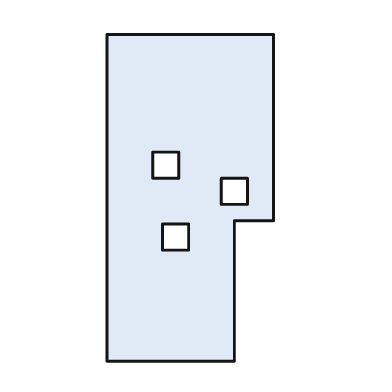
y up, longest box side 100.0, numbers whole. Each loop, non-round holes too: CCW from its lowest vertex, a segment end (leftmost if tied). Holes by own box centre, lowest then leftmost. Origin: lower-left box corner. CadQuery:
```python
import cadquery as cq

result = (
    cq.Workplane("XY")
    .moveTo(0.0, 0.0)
    .lineTo(39.0, 0.0)
    .lineTo(39.0, 43.0)
    .lineTo(51.0, 43.0)
    .lineTo(51.0, 100.0)
    .lineTo(0.0, 100.0)
    .close()
    .moveTo(17.0, 34.0)
    .lineTo(25.0, 34.0)
    .lineTo(25.0, 42.0)
    .lineTo(17.0, 42.0)
    .close()
    .moveTo(35.0, 48.0)
    .lineTo(43.0, 48.0)
    .lineTo(43.0, 56.0)
    .lineTo(35.0, 56.0)
    .close()
    .moveTo(14.0, 56.0)
    .lineTo(22.0, 56.0)
    .lineTo(22.0, 64.0)
    .lineTo(14.0, 64.0)
    .close()
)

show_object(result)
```